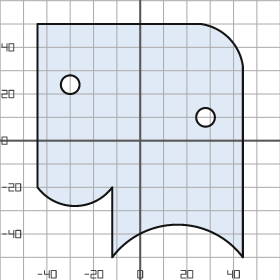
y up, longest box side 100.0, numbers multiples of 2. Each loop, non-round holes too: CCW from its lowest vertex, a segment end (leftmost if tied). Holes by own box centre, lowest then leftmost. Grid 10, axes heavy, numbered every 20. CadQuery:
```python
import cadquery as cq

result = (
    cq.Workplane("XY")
    .moveTo(-12.0, -50.0)
    .threePointArc((16.0, -36.0), (44.0, -50.0))
    .lineTo(44.0, 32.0)
    .threePointArc((38.0, 44.0), (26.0, 50.0))
    .lineTo(-44.0, 50.0)
    .lineTo(-44.0, -20.0)
    .threePointArc((-28.0, -28.0), (-12.0, -20.0))
    .close()
    .moveTo(28.0, 10.0)
    .circle(4.0)
    .moveTo(-30.0, 24.0)
    .circle(4.0)
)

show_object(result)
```